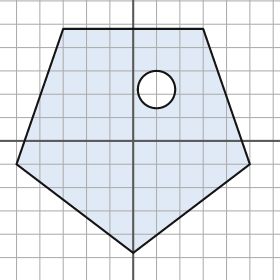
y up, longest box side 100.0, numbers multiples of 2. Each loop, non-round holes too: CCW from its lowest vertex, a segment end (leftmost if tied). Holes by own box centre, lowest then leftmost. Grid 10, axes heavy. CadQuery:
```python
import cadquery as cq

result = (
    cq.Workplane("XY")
    .moveTo(0.0, -48.0)
    .lineTo(50.0, -10.0)
    .lineTo(30.0, 48.0)
    .lineTo(-30.0, 48.0)
    .lineTo(-50.0, -10.0)
    .close()
    .moveTo(10.0, 22.0)
    .circle(8.0)
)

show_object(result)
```